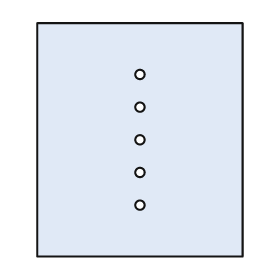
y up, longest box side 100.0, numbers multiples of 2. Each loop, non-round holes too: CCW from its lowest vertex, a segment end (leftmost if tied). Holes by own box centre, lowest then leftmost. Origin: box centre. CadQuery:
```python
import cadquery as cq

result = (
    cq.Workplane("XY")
    .moveTo(-44.0, -50.0)
    .lineTo(44.0, -50.0)
    .lineTo(44.0, 50.0)
    .lineTo(-44.0, 50.0)
    .close()
    .moveTo(0.0, -28.0)
    .circle(2.0)
    .moveTo(0.0, -14.0)
    .circle(2.0)
    .moveTo(0.0, 0.0)
    .circle(2.0)
    .moveTo(0.0, 14.0)
    .circle(2.0)
    .moveTo(0.0, 28.0)
    .circle(2.0)
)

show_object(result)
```